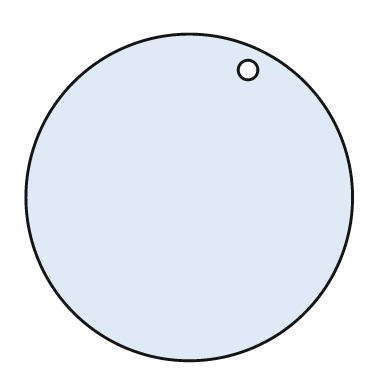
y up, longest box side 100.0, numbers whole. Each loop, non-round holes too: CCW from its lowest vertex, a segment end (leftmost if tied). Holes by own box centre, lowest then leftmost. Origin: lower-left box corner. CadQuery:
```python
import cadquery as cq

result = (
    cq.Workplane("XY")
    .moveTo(50.0, 50.0)
    .circle(50.0)
    .moveTo(68.0, 89.0)
    .circle(3.0)
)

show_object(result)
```